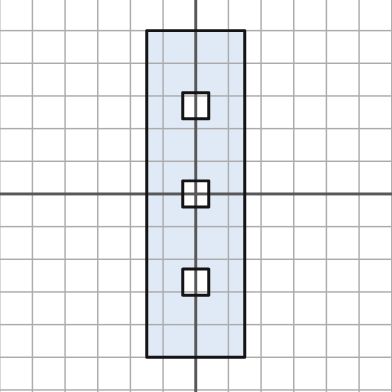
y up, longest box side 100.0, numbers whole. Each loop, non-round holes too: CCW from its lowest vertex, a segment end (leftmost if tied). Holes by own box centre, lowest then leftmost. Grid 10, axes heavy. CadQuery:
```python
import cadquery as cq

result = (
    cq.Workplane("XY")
    .moveTo(-15.0, -50.0)
    .lineTo(15.0, -50.0)
    .lineTo(15.0, 50.0)
    .lineTo(-15.0, 50.0)
    .close()
    .moveTo(-4.0, -31.0)
    .lineTo(4.0, -31.0)
    .lineTo(4.0, -23.0)
    .lineTo(-4.0, -23.0)
    .close()
    .moveTo(-4.0, -4.0)
    .lineTo(4.0, -4.0)
    .lineTo(4.0, 4.0)
    .lineTo(-4.0, 4.0)
    .close()
    .moveTo(-4.0, 23.0)
    .lineTo(4.0, 23.0)
    .lineTo(4.0, 31.0)
    .lineTo(-4.0, 31.0)
    .close()
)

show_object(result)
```